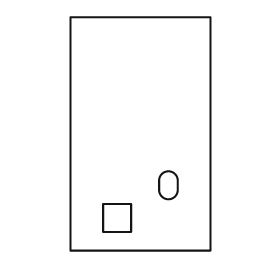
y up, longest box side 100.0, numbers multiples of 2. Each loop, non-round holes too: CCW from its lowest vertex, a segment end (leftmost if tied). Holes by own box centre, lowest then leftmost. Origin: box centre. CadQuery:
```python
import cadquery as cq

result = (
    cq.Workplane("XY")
    .moveTo(-30.0, -50.0)
    .lineTo(30.0, -50.0)
    .lineTo(30.0, 50.0)
    .lineTo(-30.0, 50.0)
    .close()
    .moveTo(-16.0, -42.0)
    .lineTo(-4.0, -42.0)
    .lineTo(-4.0, -30.0)
    .lineTo(-16.0, -30.0)
    .close()
    .moveTo(8.0, -24.0)
    .threePointArc((12.0, -28.0), (16.0, -24.0))
    .lineTo(16.0, -20.0)
    .threePointArc((12.0, -16.0), (8.0, -20.0))
    .close()
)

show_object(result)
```